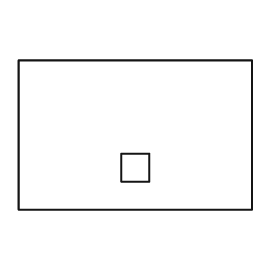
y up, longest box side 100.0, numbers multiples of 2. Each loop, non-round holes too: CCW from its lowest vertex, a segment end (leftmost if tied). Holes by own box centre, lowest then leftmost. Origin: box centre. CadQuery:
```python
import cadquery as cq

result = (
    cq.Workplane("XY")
    .moveTo(-50.0, -32.0)
    .lineTo(50.0, -32.0)
    .lineTo(50.0, 32.0)
    .lineTo(-50.0, 32.0)
    .close()
    .moveTo(-6.0, -20.0)
    .lineTo(6.0, -20.0)
    .lineTo(6.0, -8.0)
    .lineTo(-6.0, -8.0)
    .close()
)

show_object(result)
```